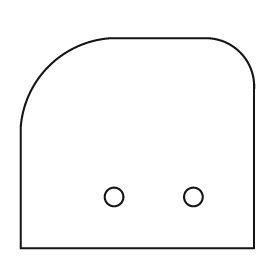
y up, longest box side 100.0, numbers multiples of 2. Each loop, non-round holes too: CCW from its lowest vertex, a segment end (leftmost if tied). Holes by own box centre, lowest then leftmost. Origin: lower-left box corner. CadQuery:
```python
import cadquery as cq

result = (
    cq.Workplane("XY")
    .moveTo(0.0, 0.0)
    .lineTo(100.0, 0.0)
    .lineTo(100.0, 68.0)
    .threePointArc((94.0, 84.0), (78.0, 90.0))
    .lineTo(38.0, 90.0)
    .threePointArc((12.0, 78.0), (0.0, 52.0))
    .close()
    .moveTo(40.0, 22.0)
    .circle(4.0)
    .moveTo(74.0, 22.0)
    .circle(4.0)
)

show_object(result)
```